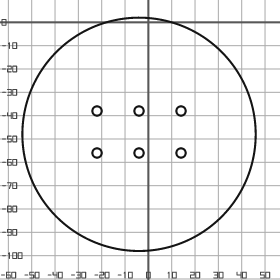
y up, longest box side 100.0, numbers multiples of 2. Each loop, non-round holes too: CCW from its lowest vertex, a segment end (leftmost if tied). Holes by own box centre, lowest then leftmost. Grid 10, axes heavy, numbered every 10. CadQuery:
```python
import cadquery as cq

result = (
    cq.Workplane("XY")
    .moveTo(-4.0, -48.0)
    .circle(50.0)
    .moveTo(-22.0, -56.0)
    .circle(2.0)
    .moveTo(-4.0, -56.0)
    .circle(2.0)
    .moveTo(14.0, -56.0)
    .circle(2.0)
    .moveTo(-22.0, -38.0)
    .circle(2.0)
    .moveTo(-4.0, -38.0)
    .circle(2.0)
    .moveTo(14.0, -38.0)
    .circle(2.0)
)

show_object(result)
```